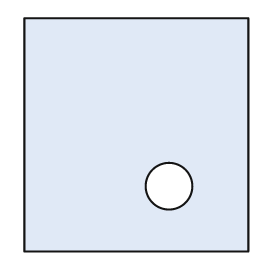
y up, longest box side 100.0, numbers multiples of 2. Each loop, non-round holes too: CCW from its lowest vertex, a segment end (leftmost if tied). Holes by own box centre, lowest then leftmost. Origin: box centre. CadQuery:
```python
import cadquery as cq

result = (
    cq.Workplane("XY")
    .moveTo(-48.0, -50.0)
    .lineTo(48.0, -50.0)
    .lineTo(48.0, 50.0)
    .lineTo(-48.0, 50.0)
    .close()
    .moveTo(14.0, -22.0)
    .circle(10.0)
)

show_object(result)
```